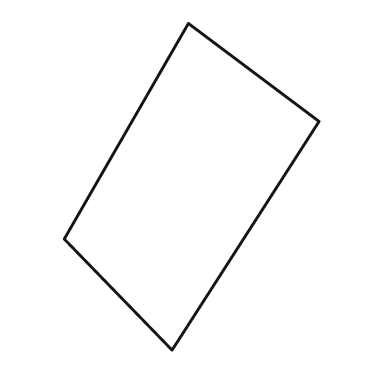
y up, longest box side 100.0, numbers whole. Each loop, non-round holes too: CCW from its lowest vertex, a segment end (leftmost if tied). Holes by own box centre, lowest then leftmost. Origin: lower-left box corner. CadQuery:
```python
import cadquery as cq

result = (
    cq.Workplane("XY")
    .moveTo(33.0, 0.0)
    .lineTo(78.0, 70.0)
    .lineTo(38.0, 100.0)
    .lineTo(0.0, 34.0)
    .close()
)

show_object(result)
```